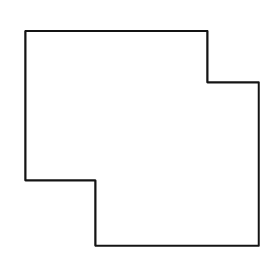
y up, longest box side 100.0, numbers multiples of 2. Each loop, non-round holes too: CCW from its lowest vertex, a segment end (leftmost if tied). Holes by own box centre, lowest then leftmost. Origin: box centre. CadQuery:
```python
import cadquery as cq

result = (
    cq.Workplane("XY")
    .moveTo(-20.0, -46.0)
    .lineTo(50.0, -46.0)
    .lineTo(50.0, 24.0)
    .lineTo(28.0, 24.0)
    .lineTo(28.0, 46.0)
    .lineTo(-50.0, 46.0)
    .lineTo(-50.0, -18.0)
    .lineTo(-20.0, -18.0)
    .close()
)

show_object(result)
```